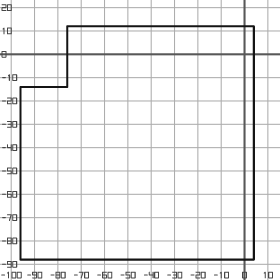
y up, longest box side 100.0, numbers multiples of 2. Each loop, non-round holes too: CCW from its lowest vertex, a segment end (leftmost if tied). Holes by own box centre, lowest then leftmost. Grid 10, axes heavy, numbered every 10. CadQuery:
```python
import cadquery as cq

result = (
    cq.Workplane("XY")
    .moveTo(-96.0, -88.0)
    .lineTo(4.0, -88.0)
    .lineTo(4.0, 12.0)
    .lineTo(-76.0, 12.0)
    .lineTo(-76.0, -14.0)
    .lineTo(-96.0, -14.0)
    .close()
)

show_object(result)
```